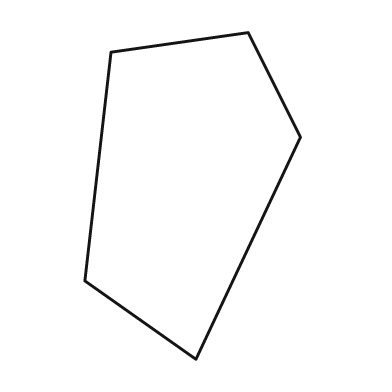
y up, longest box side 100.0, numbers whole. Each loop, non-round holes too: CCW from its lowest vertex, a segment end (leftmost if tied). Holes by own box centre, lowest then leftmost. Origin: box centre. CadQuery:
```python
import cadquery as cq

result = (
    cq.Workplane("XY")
    .moveTo(1.0, -50.0)
    .lineTo(33.0, 18.0)
    .lineTo(17.0, 50.0)
    .lineTo(-25.0, 44.0)
    .lineTo(-33.0, -26.0)
    .close()
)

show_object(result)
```